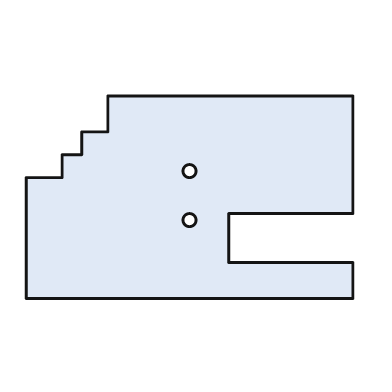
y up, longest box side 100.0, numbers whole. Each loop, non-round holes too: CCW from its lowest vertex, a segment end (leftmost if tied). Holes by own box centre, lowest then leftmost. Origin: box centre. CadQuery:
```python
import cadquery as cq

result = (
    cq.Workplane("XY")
    .moveTo(-50.0, -31.0)
    .lineTo(50.0, -31.0)
    .lineTo(50.0, -20.0)
    .lineTo(12.0, -20.0)
    .lineTo(12.0, -5.0)
    .lineTo(50.0, -5.0)
    .lineTo(50.0, 31.0)
    .lineTo(-25.0, 31.0)
    .lineTo(-25.0, 20.0)
    .lineTo(-33.0, 20.0)
    .lineTo(-33.0, 13.0)
    .lineTo(-39.0, 13.0)
    .lineTo(-39.0, 6.0)
    .lineTo(-50.0, 6.0)
    .close()
    .moveTo(0.0, -7.0)
    .circle(2.0)
    .moveTo(0.0, 8.0)
    .circle(2.0)
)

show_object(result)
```